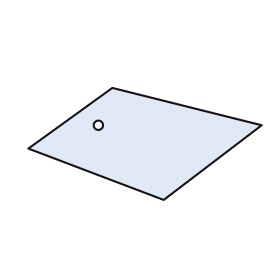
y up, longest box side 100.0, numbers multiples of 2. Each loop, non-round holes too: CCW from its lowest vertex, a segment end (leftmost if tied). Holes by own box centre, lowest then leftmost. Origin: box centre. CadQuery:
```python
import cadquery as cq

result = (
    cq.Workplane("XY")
    .moveTo(8.0, -24.0)
    .lineTo(50.0, 8.0)
    .lineTo(-14.0, 24.0)
    .lineTo(-50.0, -2.0)
    .close()
    .moveTo(-20.0, 8.0)
    .circle(2.0)
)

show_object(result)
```